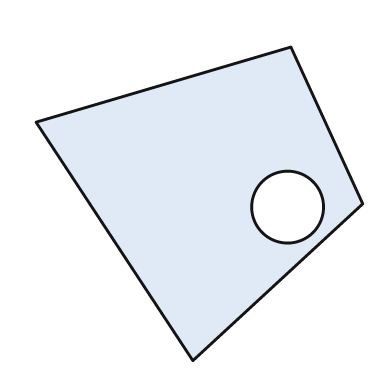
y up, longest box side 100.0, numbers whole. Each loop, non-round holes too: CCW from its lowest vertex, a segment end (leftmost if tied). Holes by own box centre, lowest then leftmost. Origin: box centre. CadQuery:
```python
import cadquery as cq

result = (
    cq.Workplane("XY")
    .moveTo(-2.0, -48.0)
    .lineTo(50.0, 0.0)
    .lineTo(28.0, 48.0)
    .lineTo(-50.0, 25.0)
    .close()
    .moveTo(27.0, -1.0)
    .circle(11.0)
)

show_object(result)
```